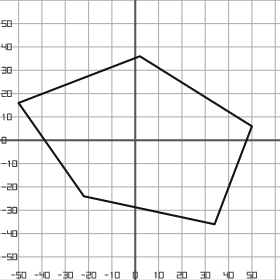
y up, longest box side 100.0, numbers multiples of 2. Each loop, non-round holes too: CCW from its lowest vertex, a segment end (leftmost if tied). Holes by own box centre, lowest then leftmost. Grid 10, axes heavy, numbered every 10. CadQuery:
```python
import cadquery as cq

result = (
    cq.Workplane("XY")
    .moveTo(34.0, -36.0)
    .lineTo(50.0, 6.0)
    .lineTo(2.0, 36.0)
    .lineTo(-50.0, 16.0)
    .lineTo(-22.0, -24.0)
    .close()
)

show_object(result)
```